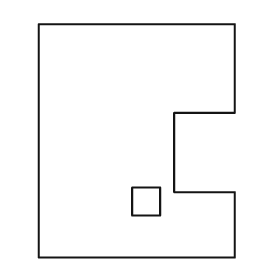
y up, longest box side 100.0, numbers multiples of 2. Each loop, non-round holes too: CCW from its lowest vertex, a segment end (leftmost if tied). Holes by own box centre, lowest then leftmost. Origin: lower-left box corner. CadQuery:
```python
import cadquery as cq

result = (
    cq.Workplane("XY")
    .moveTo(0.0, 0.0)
    .lineTo(84.0, 0.0)
    .lineTo(84.0, 28.0)
    .lineTo(58.0, 28.0)
    .lineTo(58.0, 62.0)
    .lineTo(84.0, 62.0)
    .lineTo(84.0, 100.0)
    .lineTo(0.0, 100.0)
    .close()
    .moveTo(40.0, 18.0)
    .lineTo(52.0, 18.0)
    .lineTo(52.0, 30.0)
    .lineTo(40.0, 30.0)
    .close()
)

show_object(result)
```